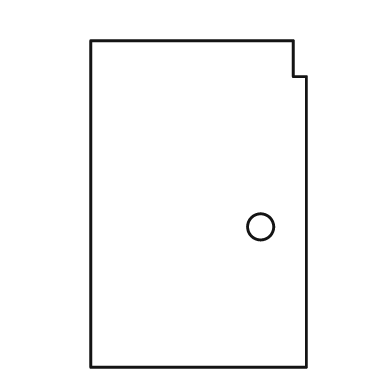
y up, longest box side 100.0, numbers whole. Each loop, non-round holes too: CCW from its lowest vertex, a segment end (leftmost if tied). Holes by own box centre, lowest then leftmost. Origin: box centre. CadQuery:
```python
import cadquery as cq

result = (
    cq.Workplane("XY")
    .moveTo(-33.0, -50.0)
    .lineTo(33.0, -50.0)
    .lineTo(33.0, 39.0)
    .lineTo(29.0, 39.0)
    .lineTo(29.0, 50.0)
    .lineTo(-33.0, 50.0)
    .close()
    .moveTo(19.0, -7.0)
    .circle(4.0)
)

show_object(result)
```